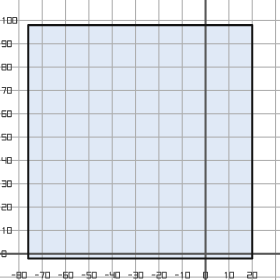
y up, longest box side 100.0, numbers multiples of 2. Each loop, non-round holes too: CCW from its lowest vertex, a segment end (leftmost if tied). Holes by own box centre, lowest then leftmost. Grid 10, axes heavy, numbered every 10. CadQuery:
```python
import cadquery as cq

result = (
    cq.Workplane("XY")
    .moveTo(-76.0, -2.0)
    .lineTo(20.0, -2.0)
    .lineTo(20.0, 98.0)
    .lineTo(-76.0, 98.0)
    .close()
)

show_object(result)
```